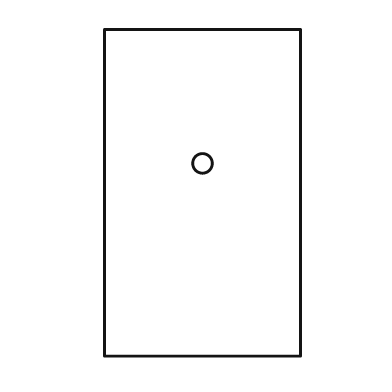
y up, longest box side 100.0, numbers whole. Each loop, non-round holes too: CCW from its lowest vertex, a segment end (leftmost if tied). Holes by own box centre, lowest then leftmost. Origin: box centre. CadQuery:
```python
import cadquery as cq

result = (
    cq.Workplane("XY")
    .moveTo(-30.0, -50.0)
    .lineTo(30.0, -50.0)
    .lineTo(30.0, 50.0)
    .lineTo(-30.0, 50.0)
    .close()
    .moveTo(0.0, 9.0)
    .circle(3.0)
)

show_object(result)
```